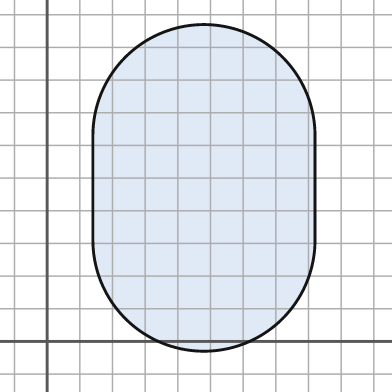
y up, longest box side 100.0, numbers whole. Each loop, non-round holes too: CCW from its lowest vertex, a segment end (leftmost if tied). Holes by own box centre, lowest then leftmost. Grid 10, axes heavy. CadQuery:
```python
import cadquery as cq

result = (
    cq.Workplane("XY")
    .moveTo(14.0, 31.0)
    .threePointArc((48.0, -3.0), (82.0, 31.0))
    .lineTo(82.0, 63.0)
    .threePointArc((48.0, 97.0), (14.0, 63.0))
    .close()
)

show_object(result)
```